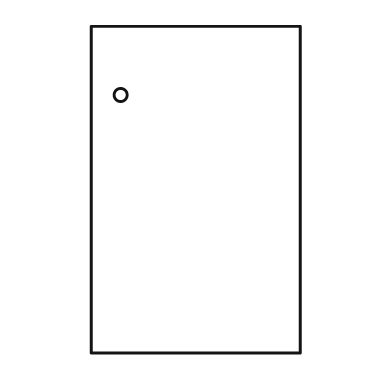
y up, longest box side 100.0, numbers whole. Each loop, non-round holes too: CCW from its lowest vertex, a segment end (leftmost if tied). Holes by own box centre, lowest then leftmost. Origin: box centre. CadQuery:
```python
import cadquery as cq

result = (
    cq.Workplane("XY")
    .moveTo(-32.0, -50.0)
    .lineTo(32.0, -50.0)
    .lineTo(32.0, 50.0)
    .lineTo(-32.0, 50.0)
    .close()
    .moveTo(-23.0, 29.0)
    .circle(2.0)
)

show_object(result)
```